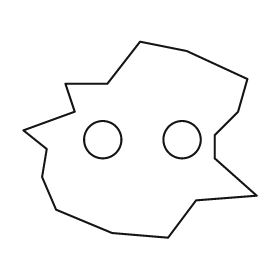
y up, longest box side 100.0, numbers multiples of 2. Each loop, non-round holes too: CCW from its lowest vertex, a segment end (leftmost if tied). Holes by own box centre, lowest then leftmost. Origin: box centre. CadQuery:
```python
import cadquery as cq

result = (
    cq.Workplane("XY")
    .moveTo(12.0, -42.0)
    .lineTo(24.0, -26.0)
    .lineTo(50.0, -24.0)
    .lineTo(32.0, -8.0)
    .lineTo(32.0, 2.0)
    .lineTo(42.0, 12.0)
    .lineTo(46.0, 26.0)
    .lineTo(20.0, 38.0)
    .lineTo(0.0, 42.0)
    .lineTo(-14.0, 24.0)
    .lineTo(-32.0, 24.0)
    .lineTo(-28.0, 12.0)
    .lineTo(-50.0, 4.0)
    .lineTo(-40.0, -4.0)
    .lineTo(-42.0, -16.0)
    .lineTo(-36.0, -30.0)
    .lineTo(-12.0, -40.0)
    .close()
    .moveTo(-16.0, 0.0)
    .circle(8.0)
    .moveTo(18.0, 0.0)
    .circle(8.0)
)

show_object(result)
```